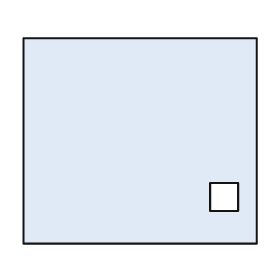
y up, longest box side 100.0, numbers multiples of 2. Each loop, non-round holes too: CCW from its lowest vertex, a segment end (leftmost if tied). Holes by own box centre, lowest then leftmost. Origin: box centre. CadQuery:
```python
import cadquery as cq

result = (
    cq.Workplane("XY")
    .moveTo(-50.0, -44.0)
    .lineTo(50.0, -44.0)
    .lineTo(50.0, 44.0)
    .lineTo(-50.0, 44.0)
    .close()
    .moveTo(30.0, -30.0)
    .lineTo(42.0, -30.0)
    .lineTo(42.0, -18.0)
    .lineTo(30.0, -18.0)
    .close()
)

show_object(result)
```